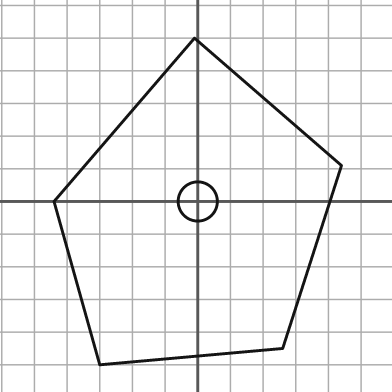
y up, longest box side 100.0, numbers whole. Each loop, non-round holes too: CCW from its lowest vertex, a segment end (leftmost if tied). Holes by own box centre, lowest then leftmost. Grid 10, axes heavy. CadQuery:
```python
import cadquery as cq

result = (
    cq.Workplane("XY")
    .moveTo(-30.0, -50.0)
    .lineTo(26.0, -45.0)
    .lineTo(44.0, 11.0)
    .lineTo(-1.0, 50.0)
    .lineTo(-44.0, 0.0)
    .close()
    .moveTo(0.0, 0.0)
    .circle(6.0)
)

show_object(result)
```